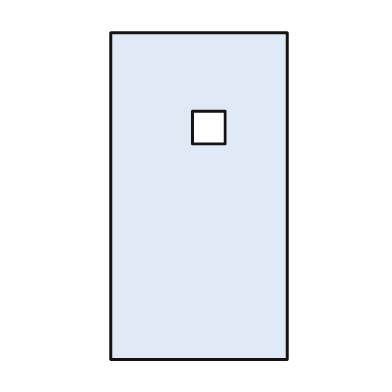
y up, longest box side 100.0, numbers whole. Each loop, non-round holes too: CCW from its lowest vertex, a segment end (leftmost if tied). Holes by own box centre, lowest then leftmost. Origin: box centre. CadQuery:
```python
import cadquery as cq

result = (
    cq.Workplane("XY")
    .moveTo(-27.0, -50.0)
    .lineTo(27.0, -50.0)
    .lineTo(27.0, 50.0)
    .lineTo(-27.0, 50.0)
    .close()
    .moveTo(-2.0, 16.0)
    .lineTo(8.0, 16.0)
    .lineTo(8.0, 26.0)
    .lineTo(-2.0, 26.0)
    .close()
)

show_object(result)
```